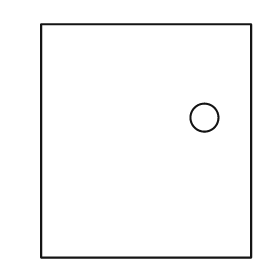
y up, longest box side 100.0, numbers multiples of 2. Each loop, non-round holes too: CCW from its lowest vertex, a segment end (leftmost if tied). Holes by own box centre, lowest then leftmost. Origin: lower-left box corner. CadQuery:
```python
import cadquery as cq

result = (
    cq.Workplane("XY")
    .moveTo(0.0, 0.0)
    .lineTo(90.0, 0.0)
    .lineTo(90.0, 100.0)
    .lineTo(0.0, 100.0)
    .close()
    .moveTo(70.0, 60.0)
    .circle(6.0)
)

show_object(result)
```